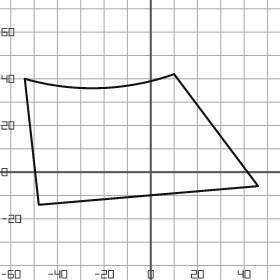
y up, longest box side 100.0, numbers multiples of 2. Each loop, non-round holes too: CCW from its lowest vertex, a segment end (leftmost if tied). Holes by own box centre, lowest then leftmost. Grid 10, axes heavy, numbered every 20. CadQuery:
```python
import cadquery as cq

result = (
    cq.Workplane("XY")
    .moveTo(-48.0, -14.0)
    .lineTo(46.0, -6.0)
    .lineTo(10.0, 42.0)
    .threePointArc((-22.0, 36.0), (-54.0, 40.0))
    .close()
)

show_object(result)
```